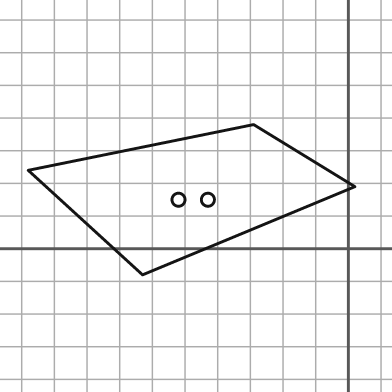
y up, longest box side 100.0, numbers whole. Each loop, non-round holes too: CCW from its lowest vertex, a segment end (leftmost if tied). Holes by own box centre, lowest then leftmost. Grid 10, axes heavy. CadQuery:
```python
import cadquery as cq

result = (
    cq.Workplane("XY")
    .moveTo(-63.0, -8.0)
    .lineTo(2.0, 19.0)
    .lineTo(-29.0, 38.0)
    .lineTo(-98.0, 24.0)
    .close()
    .moveTo(-52.0, 15.0)
    .circle(2.0)
    .moveTo(-43.0, 15.0)
    .circle(2.0)
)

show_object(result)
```